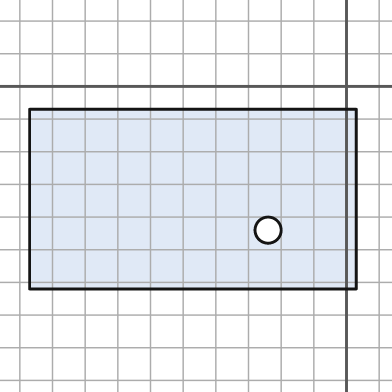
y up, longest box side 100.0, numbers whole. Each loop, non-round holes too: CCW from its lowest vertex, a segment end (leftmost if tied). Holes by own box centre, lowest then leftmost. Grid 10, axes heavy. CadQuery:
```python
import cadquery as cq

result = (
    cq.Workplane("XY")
    .moveTo(-97.0, -62.0)
    .lineTo(3.0, -62.0)
    .lineTo(3.0, -7.0)
    .lineTo(-97.0, -7.0)
    .close()
    .moveTo(-24.0, -44.0)
    .circle(4.0)
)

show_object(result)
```